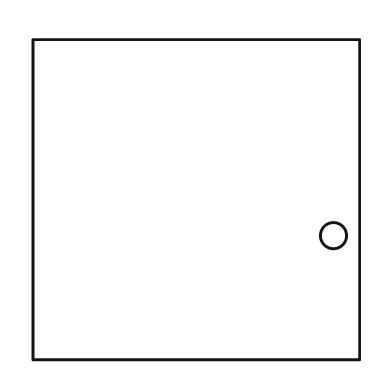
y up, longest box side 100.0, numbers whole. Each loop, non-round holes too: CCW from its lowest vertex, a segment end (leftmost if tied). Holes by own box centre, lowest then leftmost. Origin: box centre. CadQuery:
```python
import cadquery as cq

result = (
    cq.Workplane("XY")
    .moveTo(-50.0, -49.0)
    .lineTo(50.0, -49.0)
    .lineTo(50.0, 49.0)
    .lineTo(-50.0, 49.0)
    .close()
    .moveTo(42.0, -11.0)
    .circle(4.0)
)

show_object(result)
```